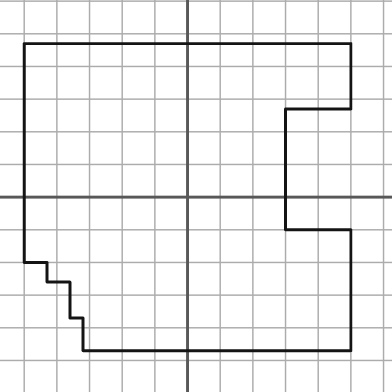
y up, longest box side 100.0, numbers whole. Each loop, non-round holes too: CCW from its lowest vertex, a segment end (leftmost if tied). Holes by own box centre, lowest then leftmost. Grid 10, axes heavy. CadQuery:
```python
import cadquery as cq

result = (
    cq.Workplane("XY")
    .moveTo(-32.0, -47.0)
    .lineTo(50.0, -47.0)
    .lineTo(50.0, -10.0)
    .lineTo(30.0, -10.0)
    .lineTo(30.0, 27.0)
    .lineTo(50.0, 27.0)
    .lineTo(50.0, 47.0)
    .lineTo(-50.0, 47.0)
    .lineTo(-50.0, -20.0)
    .lineTo(-43.0, -20.0)
    .lineTo(-43.0, -26.0)
    .lineTo(-36.0, -26.0)
    .lineTo(-36.0, -37.0)
    .lineTo(-32.0, -37.0)
    .close()
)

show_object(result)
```